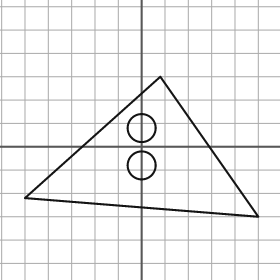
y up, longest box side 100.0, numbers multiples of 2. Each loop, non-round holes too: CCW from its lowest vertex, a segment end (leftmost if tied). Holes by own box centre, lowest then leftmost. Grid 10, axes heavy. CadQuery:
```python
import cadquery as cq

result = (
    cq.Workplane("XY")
    .moveTo(50.0, -30.0)
    .lineTo(8.0, 30.0)
    .lineTo(-50.0, -22.0)
    .close()
    .moveTo(0.0, -8.0)
    .circle(6.0)
    .moveTo(0.0, 8.0)
    .circle(6.0)
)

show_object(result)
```